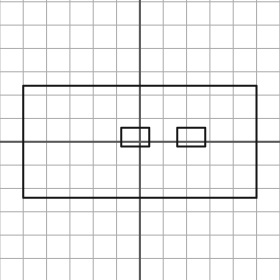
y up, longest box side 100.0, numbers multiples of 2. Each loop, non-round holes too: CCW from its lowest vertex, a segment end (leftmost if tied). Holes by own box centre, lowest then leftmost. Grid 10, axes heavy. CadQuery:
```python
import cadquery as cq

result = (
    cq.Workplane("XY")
    .moveTo(-50.0, -24.0)
    .lineTo(50.0, -24.0)
    .lineTo(50.0, 24.0)
    .lineTo(-50.0, 24.0)
    .close()
    .moveTo(-8.0, -2.0)
    .lineTo(4.0, -2.0)
    .lineTo(4.0, 6.0)
    .lineTo(-8.0, 6.0)
    .close()
    .moveTo(16.0, -2.0)
    .lineTo(28.0, -2.0)
    .lineTo(28.0, 6.0)
    .lineTo(16.0, 6.0)
    .close()
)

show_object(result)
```